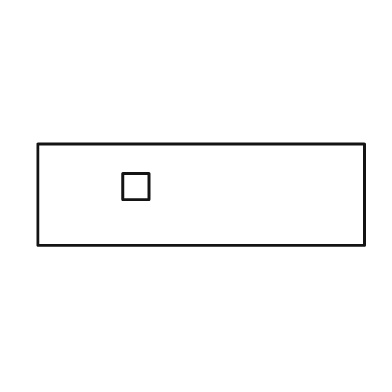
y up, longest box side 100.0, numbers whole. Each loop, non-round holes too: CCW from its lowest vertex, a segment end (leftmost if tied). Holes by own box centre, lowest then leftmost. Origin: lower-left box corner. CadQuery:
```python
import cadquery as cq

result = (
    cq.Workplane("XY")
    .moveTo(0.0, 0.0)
    .lineTo(100.0, 0.0)
    .lineTo(100.0, 31.0)
    .lineTo(0.0, 31.0)
    .close()
    .moveTo(26.0, 14.0)
    .lineTo(34.0, 14.0)
    .lineTo(34.0, 22.0)
    .lineTo(26.0, 22.0)
    .close()
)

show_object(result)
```